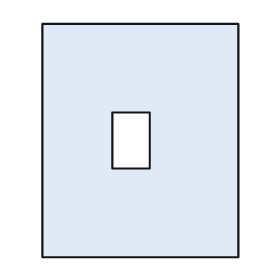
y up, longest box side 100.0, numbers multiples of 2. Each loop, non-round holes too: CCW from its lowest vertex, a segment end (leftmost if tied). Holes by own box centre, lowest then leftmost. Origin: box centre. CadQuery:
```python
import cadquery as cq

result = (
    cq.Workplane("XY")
    .moveTo(-42.0, -50.0)
    .lineTo(42.0, -50.0)
    .lineTo(42.0, 50.0)
    .lineTo(-42.0, 50.0)
    .close()
    .moveTo(-12.0, -12.0)
    .lineTo(4.0, -12.0)
    .lineTo(4.0, 12.0)
    .lineTo(-12.0, 12.0)
    .close()
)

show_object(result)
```